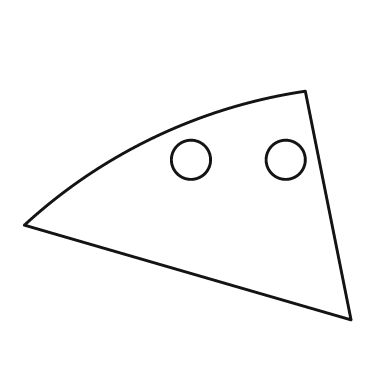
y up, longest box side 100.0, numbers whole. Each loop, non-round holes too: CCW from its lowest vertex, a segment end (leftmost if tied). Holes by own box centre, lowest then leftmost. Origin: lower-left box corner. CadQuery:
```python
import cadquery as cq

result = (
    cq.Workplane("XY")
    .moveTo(100.0, 0.0)
    .lineTo(86.0, 70.0)
    .threePointArc((40.0, 56.0), (0.0, 29.0))
    .close()
    .moveTo(51.0, 49.0)
    .circle(6.0)
    .moveTo(80.0, 49.0)
    .circle(6.0)
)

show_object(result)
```